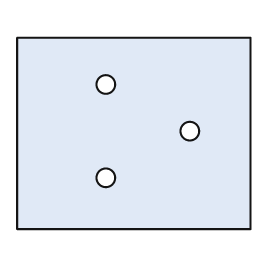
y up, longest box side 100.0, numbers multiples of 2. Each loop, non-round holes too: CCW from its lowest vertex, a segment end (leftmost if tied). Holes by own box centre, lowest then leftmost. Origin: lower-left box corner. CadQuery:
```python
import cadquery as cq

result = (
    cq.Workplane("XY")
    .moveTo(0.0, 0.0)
    .lineTo(100.0, 0.0)
    .lineTo(100.0, 82.0)
    .lineTo(0.0, 82.0)
    .close()
    .moveTo(38.0, 22.0)
    .circle(4.0)
    .moveTo(74.0, 42.0)
    .circle(4.0)
    .moveTo(38.0, 62.0)
    .circle(4.0)
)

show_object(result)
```